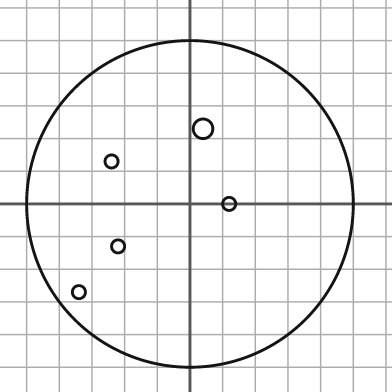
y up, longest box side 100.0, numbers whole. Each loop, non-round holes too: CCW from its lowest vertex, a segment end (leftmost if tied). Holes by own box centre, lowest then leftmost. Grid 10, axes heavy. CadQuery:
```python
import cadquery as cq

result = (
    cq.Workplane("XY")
    .moveTo(0.0, 0.0)
    .circle(50.0)
    .moveTo(-34.0, -27.0)
    .circle(2.0)
    .moveTo(-22.0, -13.0)
    .circle(2.0)
    .moveTo(12.0, 0.0)
    .circle(2.0)
    .moveTo(-24.0, 13.0)
    .circle(2.0)
    .moveTo(4.0, 23.0)
    .circle(3.0)
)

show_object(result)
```